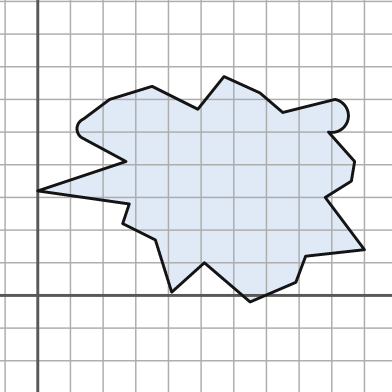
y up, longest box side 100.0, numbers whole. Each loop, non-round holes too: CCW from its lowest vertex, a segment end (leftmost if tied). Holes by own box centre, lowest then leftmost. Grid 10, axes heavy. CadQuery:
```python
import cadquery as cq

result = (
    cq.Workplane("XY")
    .moveTo(65.0, -2.0)
    .lineTo(79.0, 4.0)
    .lineTo(82.0, 12.0)
    .lineTo(100.0, 14.0)
    .lineTo(88.0, 30.0)
    .lineTo(96.0, 35.0)
    .lineTo(97.0, 41.0)
    .lineTo(89.0, 50.0)
    .threePointArc((95.0, 54.0), (91.0, 60.0))
    .lineTo(75.0, 56.0)
    .lineTo(68.0, 62.0)
    .lineTo(57.0, 67.0)
    .lineTo(49.0, 57.0)
    .lineTo(35.0, 64.0)
    .lineTo(22.0, 60.0)
    .lineTo(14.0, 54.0)
    .threePointArc((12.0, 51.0), (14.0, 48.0))
    .lineTo(27.0, 41.0)
    .lineTo(0.0, 32.0)
    .lineTo(28.0, 28.0)
    .lineTo(26.0, 22.0)
    .lineTo(36.0, 17.0)
    .lineTo(41.0, 1.0)
    .lineTo(51.0, 10.0)
    .close()
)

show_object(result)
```